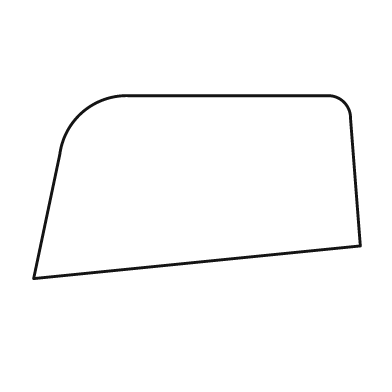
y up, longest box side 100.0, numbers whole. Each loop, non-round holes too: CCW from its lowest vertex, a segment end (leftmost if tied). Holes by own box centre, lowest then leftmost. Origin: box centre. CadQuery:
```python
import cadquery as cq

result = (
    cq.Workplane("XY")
    .moveTo(-50.0, -28.0)
    .lineTo(50.0, -18.0)
    .lineTo(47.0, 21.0)
    .threePointArc((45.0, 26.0), (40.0, 28.0))
    .lineTo(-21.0, 28.0)
    .threePointArc((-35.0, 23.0), (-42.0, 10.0))
    .close()
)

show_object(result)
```